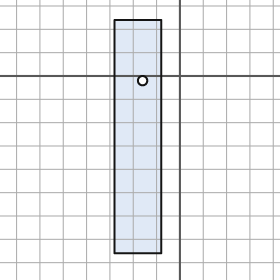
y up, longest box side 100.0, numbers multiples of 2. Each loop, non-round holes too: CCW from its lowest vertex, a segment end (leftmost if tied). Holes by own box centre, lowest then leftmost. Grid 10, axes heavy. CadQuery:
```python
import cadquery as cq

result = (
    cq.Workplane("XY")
    .moveTo(-28.0, -76.0)
    .lineTo(-8.0, -76.0)
    .lineTo(-8.0, 24.0)
    .lineTo(-28.0, 24.0)
    .close()
    .moveTo(-16.0, -2.0)
    .circle(2.0)
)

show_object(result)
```